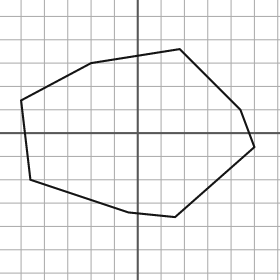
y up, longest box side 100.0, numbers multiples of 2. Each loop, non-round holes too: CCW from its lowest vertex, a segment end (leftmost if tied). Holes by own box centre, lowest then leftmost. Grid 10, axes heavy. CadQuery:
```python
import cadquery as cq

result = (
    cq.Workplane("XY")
    .moveTo(16.0, -36.0)
    .lineTo(50.0, -6.0)
    .lineTo(44.0, 10.0)
    .lineTo(18.0, 36.0)
    .lineTo(-20.0, 30.0)
    .lineTo(-50.0, 14.0)
    .lineTo(-46.0, -20.0)
    .lineTo(-4.0, -34.0)
    .close()
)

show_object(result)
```